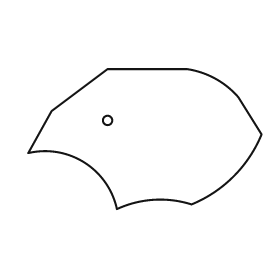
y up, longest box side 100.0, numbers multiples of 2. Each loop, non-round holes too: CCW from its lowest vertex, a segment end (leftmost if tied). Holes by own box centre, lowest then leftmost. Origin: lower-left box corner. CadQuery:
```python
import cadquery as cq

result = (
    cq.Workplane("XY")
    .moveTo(38.0, 0.0)
    .threePointArc((54.0, 4.0), (70.0, 2.0))
    .threePointArc((88.0, 14.0), (100.0, 32.0))
    .lineTo(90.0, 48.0)
    .threePointArc((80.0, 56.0), (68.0, 60.0))
    .lineTo(34.0, 60.0)
    .lineTo(10.0, 42.0)
    .lineTo(0.0, 24.0)
    .threePointArc((24.0, 20.0), (38.0, 0.0))
    .close()
    .moveTo(34.0, 38.0)
    .circle(2.0)
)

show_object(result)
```